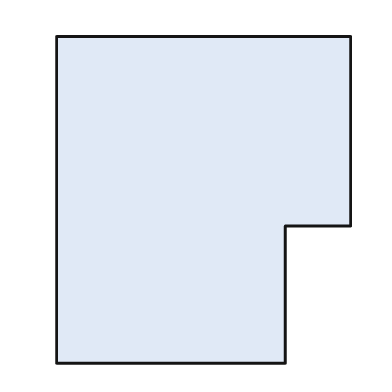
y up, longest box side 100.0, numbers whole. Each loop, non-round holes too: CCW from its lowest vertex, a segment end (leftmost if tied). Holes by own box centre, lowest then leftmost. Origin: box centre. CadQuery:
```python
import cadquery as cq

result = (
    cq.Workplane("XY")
    .moveTo(-45.0, -50.0)
    .lineTo(25.0, -50.0)
    .lineTo(25.0, -8.0)
    .lineTo(45.0, -8.0)
    .lineTo(45.0, 50.0)
    .lineTo(-45.0, 50.0)
    .close()
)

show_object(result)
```